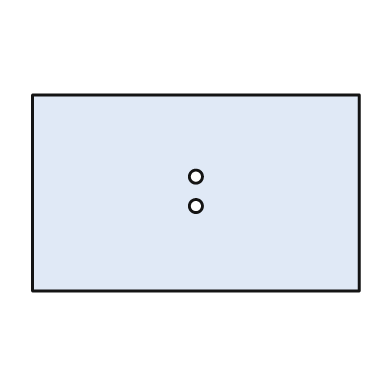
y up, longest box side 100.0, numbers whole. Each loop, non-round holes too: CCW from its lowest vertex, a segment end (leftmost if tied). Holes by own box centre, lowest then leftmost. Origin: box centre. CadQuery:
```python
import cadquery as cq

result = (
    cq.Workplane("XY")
    .moveTo(-50.0, -30.0)
    .lineTo(50.0, -30.0)
    .lineTo(50.0, 30.0)
    .lineTo(-50.0, 30.0)
    .close()
    .moveTo(0.0, -4.0)
    .circle(2.0)
    .moveTo(0.0, 5.0)
    .circle(2.0)
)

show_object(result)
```